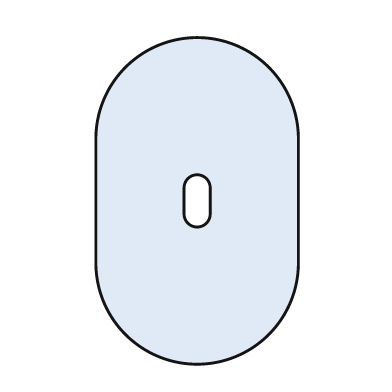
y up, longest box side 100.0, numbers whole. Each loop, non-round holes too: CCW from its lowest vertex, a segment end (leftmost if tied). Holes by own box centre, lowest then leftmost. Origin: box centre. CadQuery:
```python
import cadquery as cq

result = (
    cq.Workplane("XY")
    .moveTo(-31.0, -19.0)
    .threePointArc((0.0, -50.0), (31.0, -19.0))
    .lineTo(31.0, 19.0)
    .threePointArc((0.0, 50.0), (-31.0, 19.0))
    .close()
    .moveTo(-4.0, -4.0)
    .threePointArc((0.0, -8.0), (4.0, -4.0))
    .lineTo(4.0, 4.0)
    .threePointArc((0.0, 8.0), (-4.0, 4.0))
    .close()
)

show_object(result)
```